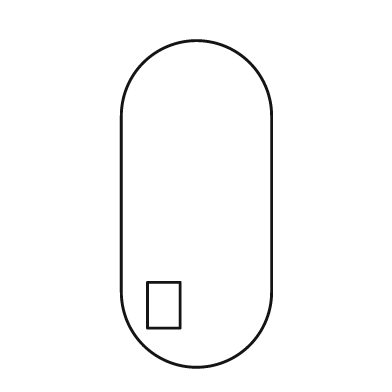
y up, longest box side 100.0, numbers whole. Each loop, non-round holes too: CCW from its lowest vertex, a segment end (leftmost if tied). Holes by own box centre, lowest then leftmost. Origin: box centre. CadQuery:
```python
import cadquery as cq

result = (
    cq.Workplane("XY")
    .moveTo(-23.0, -27.0)
    .threePointArc((0.0, -50.0), (23.0, -27.0))
    .lineTo(23.0, 27.0)
    .threePointArc((0.0, 50.0), (-23.0, 27.0))
    .close()
    .moveTo(-15.0, -38.0)
    .lineTo(-5.0, -38.0)
    .lineTo(-5.0, -24.0)
    .lineTo(-15.0, -24.0)
    .close()
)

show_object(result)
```